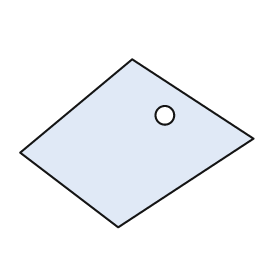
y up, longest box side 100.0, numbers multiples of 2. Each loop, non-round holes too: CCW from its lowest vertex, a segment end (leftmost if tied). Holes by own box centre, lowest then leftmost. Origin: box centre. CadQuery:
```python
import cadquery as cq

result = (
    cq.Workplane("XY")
    .moveTo(-8.0, -36.0)
    .lineTo(50.0, 2.0)
    .lineTo(-2.0, 36.0)
    .lineTo(-50.0, -4.0)
    .close()
    .moveTo(12.0, 12.0)
    .circle(4.0)
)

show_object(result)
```